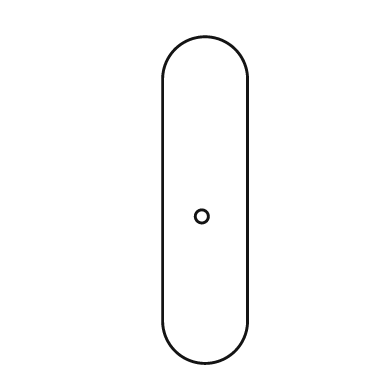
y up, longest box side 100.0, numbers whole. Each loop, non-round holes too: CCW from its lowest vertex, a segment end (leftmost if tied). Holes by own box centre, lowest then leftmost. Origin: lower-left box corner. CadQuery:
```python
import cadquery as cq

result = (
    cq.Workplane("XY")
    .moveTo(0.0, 13.0)
    .threePointArc((13.0, 0.0), (26.0, 13.0))
    .lineTo(26.0, 87.0)
    .threePointArc((13.0, 100.0), (0.0, 87.0))
    .close()
    .moveTo(12.0, 45.0)
    .circle(2.0)
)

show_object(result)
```